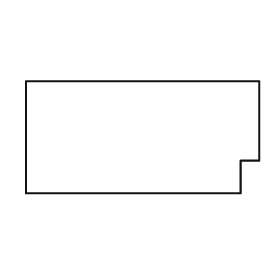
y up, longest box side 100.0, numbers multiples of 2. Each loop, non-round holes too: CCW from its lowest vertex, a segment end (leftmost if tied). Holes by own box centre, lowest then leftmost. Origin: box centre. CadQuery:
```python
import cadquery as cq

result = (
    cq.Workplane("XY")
    .moveTo(-50.0, -24.0)
    .lineTo(42.0, -24.0)
    .lineTo(42.0, -10.0)
    .lineTo(50.0, -10.0)
    .lineTo(50.0, 24.0)
    .lineTo(-50.0, 24.0)
    .close()
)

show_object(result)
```